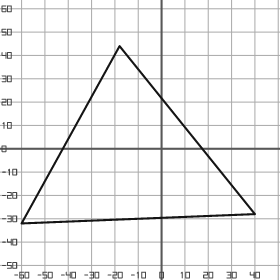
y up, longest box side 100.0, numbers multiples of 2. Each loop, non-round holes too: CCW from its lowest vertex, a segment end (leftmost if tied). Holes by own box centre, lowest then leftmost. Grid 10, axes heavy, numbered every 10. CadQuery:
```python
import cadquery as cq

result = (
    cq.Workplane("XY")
    .moveTo(-60.0, -32.0)
    .lineTo(40.0, -28.0)
    .lineTo(-18.0, 44.0)
    .close()
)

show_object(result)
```